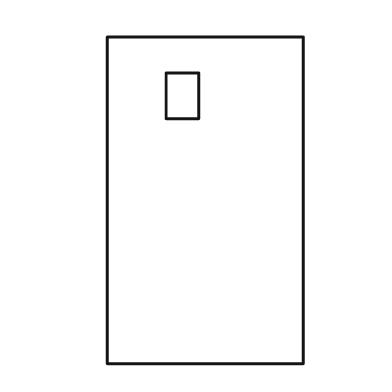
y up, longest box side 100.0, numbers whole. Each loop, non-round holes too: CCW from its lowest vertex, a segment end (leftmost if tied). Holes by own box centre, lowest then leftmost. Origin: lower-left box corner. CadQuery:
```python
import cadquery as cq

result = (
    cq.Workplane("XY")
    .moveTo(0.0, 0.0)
    .lineTo(60.0, 0.0)
    .lineTo(60.0, 100.0)
    .lineTo(0.0, 100.0)
    .close()
    .moveTo(18.0, 75.0)
    .lineTo(28.0, 75.0)
    .lineTo(28.0, 89.0)
    .lineTo(18.0, 89.0)
    .close()
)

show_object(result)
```